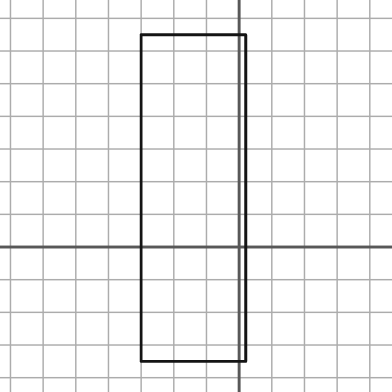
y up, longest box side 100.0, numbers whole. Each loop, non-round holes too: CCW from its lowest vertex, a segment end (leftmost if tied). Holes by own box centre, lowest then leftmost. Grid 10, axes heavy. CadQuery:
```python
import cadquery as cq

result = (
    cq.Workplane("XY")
    .moveTo(-30.0, -35.0)
    .lineTo(2.0, -35.0)
    .lineTo(2.0, 65.0)
    .lineTo(-30.0, 65.0)
    .close()
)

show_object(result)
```